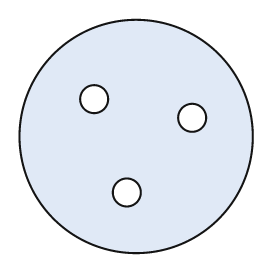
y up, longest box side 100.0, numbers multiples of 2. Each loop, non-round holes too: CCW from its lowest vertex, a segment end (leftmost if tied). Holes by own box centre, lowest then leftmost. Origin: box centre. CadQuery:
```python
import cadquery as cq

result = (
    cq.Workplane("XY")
    .moveTo(0.0, 0.0)
    .circle(50.0)
    .moveTo(-4.0, -24.0)
    .circle(6.0)
    .moveTo(24.0, 8.0)
    .circle(6.0)
    .moveTo(-18.0, 16.0)
    .circle(6.0)
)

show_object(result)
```